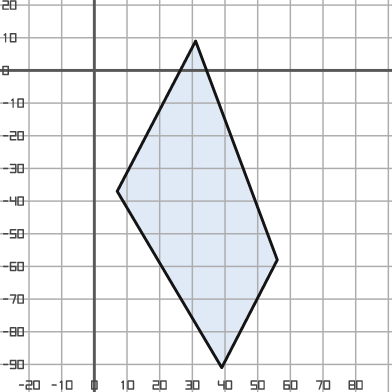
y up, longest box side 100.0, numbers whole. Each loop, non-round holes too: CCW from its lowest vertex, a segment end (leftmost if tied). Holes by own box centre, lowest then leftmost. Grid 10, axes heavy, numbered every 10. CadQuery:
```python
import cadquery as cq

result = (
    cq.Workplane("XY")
    .moveTo(39.0, -91.0)
    .lineTo(56.0, -58.0)
    .lineTo(31.0, 9.0)
    .lineTo(7.0, -37.0)
    .close()
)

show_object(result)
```